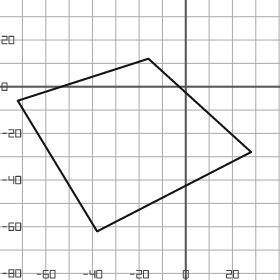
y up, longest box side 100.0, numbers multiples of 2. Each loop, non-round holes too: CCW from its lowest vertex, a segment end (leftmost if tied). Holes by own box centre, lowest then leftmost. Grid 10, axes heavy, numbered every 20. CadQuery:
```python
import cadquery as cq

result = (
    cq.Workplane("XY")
    .moveTo(-38.0, -62.0)
    .lineTo(28.0, -28.0)
    .lineTo(-16.0, 12.0)
    .lineTo(-72.0, -6.0)
    .close()
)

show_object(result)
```